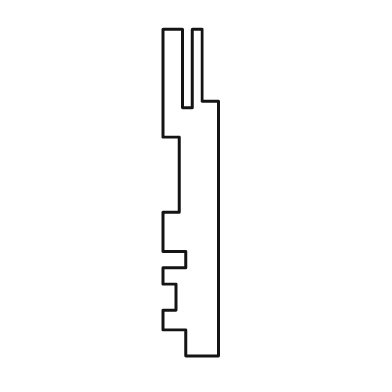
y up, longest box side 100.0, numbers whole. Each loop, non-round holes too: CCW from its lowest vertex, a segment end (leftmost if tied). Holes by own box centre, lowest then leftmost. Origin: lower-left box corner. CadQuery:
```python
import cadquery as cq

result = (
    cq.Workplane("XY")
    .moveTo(7.0, 0.0)
    .lineTo(17.0, 0.0)
    .lineTo(17.0, 78.0)
    .lineTo(12.0, 78.0)
    .lineTo(12.0, 100.0)
    .lineTo(9.0, 100.0)
    .lineTo(9.0, 76.0)
    .lineTo(6.0, 76.0)
    .lineTo(6.0, 100.0)
    .lineTo(0.0, 100.0)
    .lineTo(0.0, 67.0)
    .lineTo(5.0, 67.0)
    .lineTo(5.0, 44.0)
    .lineTo(0.0, 44.0)
    .lineTo(0.0, 32.0)
    .lineTo(7.0, 32.0)
    .lineTo(7.0, 27.0)
    .lineTo(0.0, 27.0)
    .lineTo(0.0, 22.0)
    .lineTo(4.0, 22.0)
    .lineTo(4.0, 14.0)
    .lineTo(0.0, 14.0)
    .lineTo(0.0, 8.0)
    .lineTo(7.0, 8.0)
    .close()
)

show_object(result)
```